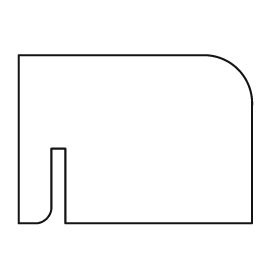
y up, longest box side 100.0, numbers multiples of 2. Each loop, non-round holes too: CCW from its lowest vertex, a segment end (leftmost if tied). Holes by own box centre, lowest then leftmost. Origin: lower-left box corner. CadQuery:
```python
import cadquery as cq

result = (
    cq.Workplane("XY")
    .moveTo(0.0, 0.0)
    .lineTo(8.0, 0.0)
    .threePointArc((12.0, 2.0), (14.0, 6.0))
    .lineTo(14.0, 32.0)
    .lineTo(20.0, 32.0)
    .lineTo(20.0, 0.0)
    .lineTo(100.0, 0.0)
    .lineTo(100.0, 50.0)
    .threePointArc((94.0, 66.0), (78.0, 72.0))
    .lineTo(0.0, 72.0)
    .close()
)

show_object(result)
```